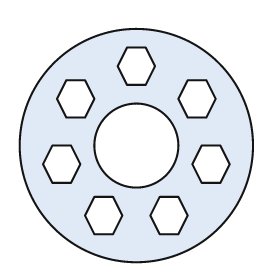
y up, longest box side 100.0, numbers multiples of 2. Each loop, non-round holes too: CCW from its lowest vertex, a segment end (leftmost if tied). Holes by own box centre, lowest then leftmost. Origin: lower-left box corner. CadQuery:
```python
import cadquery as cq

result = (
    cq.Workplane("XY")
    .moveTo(50.0, 50.0)
    .circle(50.0)
    .moveTo(32.0, 12.0)
    .lineTo(40.0, 12.0)
    .lineTo(44.0, 20.0)
    .lineTo(40.0, 28.0)
    .lineTo(32.0, 28.0)
    .lineTo(28.0, 20.0)
    .close()
    .moveTo(60.0, 12.0)
    .lineTo(68.0, 12.0)
    .lineTo(72.0, 20.0)
    .lineTo(68.0, 28.0)
    .lineTo(60.0, 28.0)
    .lineTo(56.0, 20.0)
    .close()
    .moveTo(14.0, 34.0)
    .lineTo(22.0, 34.0)
    .lineTo(26.0, 42.0)
    .lineTo(22.0, 50.0)
    .lineTo(14.0, 50.0)
    .lineTo(10.0, 42.0)
    .close()
    .moveTo(78.0, 34.0)
    .lineTo(86.0, 34.0)
    .lineTo(90.0, 42.0)
    .lineTo(86.0, 50.0)
    .lineTo(78.0, 50.0)
    .lineTo(74.0, 42.0)
    .close()
    .moveTo(50.0, 50.0)
    .circle(18.0)
    .moveTo(20.0, 62.0)
    .lineTo(28.0, 62.0)
    .lineTo(32.0, 70.0)
    .lineTo(28.0, 78.0)
    .lineTo(20.0, 78.0)
    .lineTo(16.0, 70.0)
    .close()
    .moveTo(72.0, 62.0)
    .lineTo(80.0, 62.0)
    .lineTo(84.0, 70.0)
    .lineTo(80.0, 78.0)
    .lineTo(72.0, 78.0)
    .lineTo(68.0, 70.0)
    .close()
    .moveTo(46.0, 76.0)
    .lineTo(54.0, 76.0)
    .lineTo(58.0, 84.0)
    .lineTo(54.0, 92.0)
    .lineTo(46.0, 92.0)
    .lineTo(42.0, 84.0)
    .close()
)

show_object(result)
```